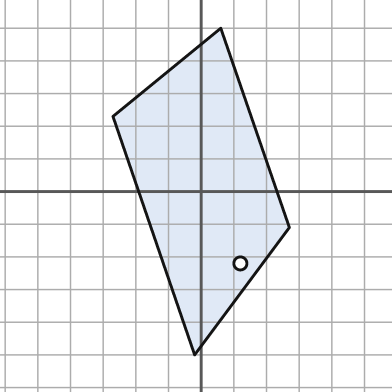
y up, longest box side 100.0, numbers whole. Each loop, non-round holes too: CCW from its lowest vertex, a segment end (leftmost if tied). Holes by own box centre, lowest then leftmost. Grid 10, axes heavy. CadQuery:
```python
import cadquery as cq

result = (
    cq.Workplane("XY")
    .moveTo(-2.0, -50.0)
    .lineTo(27.0, -11.0)
    .lineTo(6.0, 50.0)
    .lineTo(-27.0, 23.0)
    .close()
    .moveTo(12.0, -22.0)
    .circle(2.0)
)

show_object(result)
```